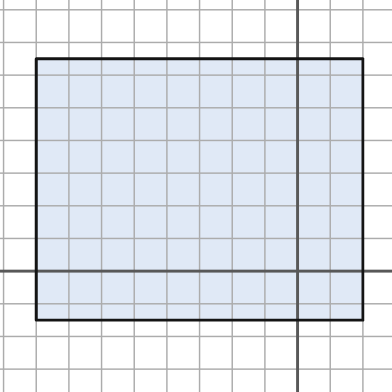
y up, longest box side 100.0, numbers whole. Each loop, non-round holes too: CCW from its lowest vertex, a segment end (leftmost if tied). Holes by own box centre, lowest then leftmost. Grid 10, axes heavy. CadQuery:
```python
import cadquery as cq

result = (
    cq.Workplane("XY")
    .moveTo(-80.0, -15.0)
    .lineTo(20.0, -15.0)
    .lineTo(20.0, 65.0)
    .lineTo(-80.0, 65.0)
    .close()
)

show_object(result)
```